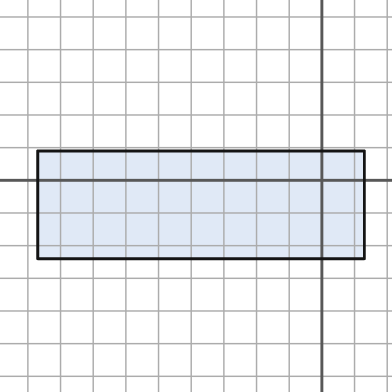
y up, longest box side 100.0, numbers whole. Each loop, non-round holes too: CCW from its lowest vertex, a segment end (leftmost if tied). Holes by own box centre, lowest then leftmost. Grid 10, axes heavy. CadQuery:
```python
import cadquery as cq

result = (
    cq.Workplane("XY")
    .moveTo(-87.0, -24.0)
    .lineTo(13.0, -24.0)
    .lineTo(13.0, 9.0)
    .lineTo(-87.0, 9.0)
    .close()
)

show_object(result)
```